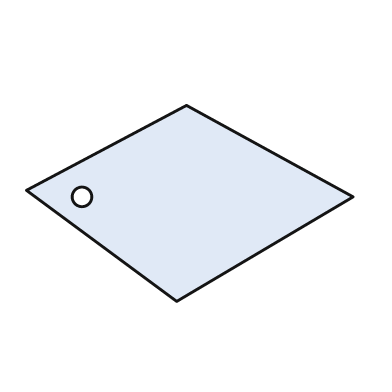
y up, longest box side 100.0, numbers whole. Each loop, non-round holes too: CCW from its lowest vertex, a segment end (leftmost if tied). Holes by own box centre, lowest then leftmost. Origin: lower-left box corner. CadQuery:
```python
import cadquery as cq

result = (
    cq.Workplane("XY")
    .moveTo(46.0, 0.0)
    .lineTo(100.0, 32.0)
    .lineTo(49.0, 60.0)
    .lineTo(0.0, 34.0)
    .close()
    .moveTo(17.0, 32.0)
    .circle(3.0)
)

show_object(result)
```